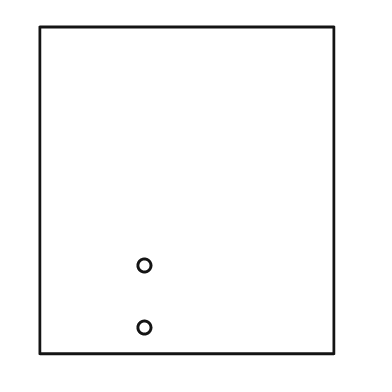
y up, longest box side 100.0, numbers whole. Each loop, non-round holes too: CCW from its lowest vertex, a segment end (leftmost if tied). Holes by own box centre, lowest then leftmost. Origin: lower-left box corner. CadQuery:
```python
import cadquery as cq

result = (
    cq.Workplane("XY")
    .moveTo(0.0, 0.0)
    .lineTo(90.0, 0.0)
    .lineTo(90.0, 100.0)
    .lineTo(0.0, 100.0)
    .close()
    .moveTo(32.0, 8.0)
    .circle(2.0)
    .moveTo(32.0, 27.0)
    .circle(2.0)
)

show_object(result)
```